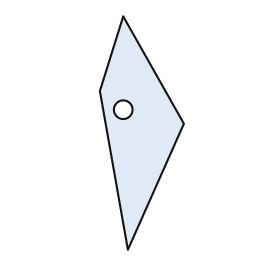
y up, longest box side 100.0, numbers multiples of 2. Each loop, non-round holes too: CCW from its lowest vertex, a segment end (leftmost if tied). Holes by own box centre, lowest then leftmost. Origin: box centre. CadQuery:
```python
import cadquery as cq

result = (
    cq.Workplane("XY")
    .moveTo(-6.0, -50.0)
    .lineTo(18.0, 4.0)
    .lineTo(-8.0, 50.0)
    .lineTo(-18.0, 18.0)
    .close()
    .moveTo(-8.0, 10.0)
    .circle(4.0)
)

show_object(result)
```